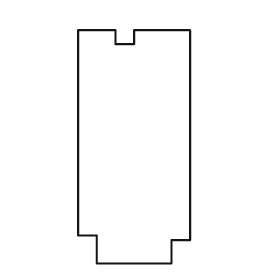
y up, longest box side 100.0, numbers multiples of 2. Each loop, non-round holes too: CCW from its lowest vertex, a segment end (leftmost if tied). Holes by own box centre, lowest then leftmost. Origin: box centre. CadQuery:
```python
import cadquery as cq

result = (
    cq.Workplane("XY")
    .moveTo(-16.0, -50.0)
    .lineTo(16.0, -50.0)
    .lineTo(16.0, -40.0)
    .lineTo(24.0, -40.0)
    .lineTo(24.0, 50.0)
    .lineTo(0.0, 50.0)
    .lineTo(0.0, 44.0)
    .lineTo(-8.0, 44.0)
    .lineTo(-8.0, 50.0)
    .lineTo(-24.0, 50.0)
    .lineTo(-24.0, -38.0)
    .lineTo(-16.0, -38.0)
    .close()
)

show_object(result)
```